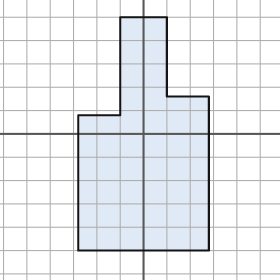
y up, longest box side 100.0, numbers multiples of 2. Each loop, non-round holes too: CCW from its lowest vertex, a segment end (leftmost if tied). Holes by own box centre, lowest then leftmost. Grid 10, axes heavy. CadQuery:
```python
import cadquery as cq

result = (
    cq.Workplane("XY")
    .moveTo(-28.0, -50.0)
    .lineTo(28.0, -50.0)
    .lineTo(28.0, 16.0)
    .lineTo(10.0, 16.0)
    .lineTo(10.0, 50.0)
    .lineTo(-10.0, 50.0)
    .lineTo(-10.0, 8.0)
    .lineTo(-28.0, 8.0)
    .close()
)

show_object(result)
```